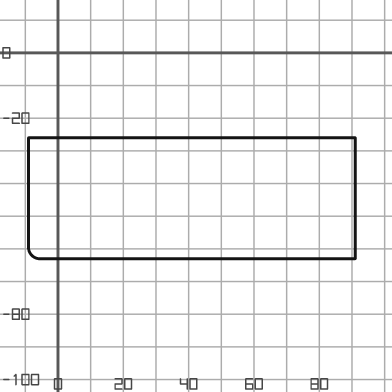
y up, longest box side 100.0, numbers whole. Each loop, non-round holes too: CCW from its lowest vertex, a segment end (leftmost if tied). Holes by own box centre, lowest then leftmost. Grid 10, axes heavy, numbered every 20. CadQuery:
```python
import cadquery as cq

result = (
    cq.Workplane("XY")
    .moveTo(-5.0, -63.0)
    .lineTo(91.0, -63.0)
    .lineTo(91.0, -26.0)
    .lineTo(-9.0, -26.0)
    .lineTo(-9.0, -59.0)
    .threePointArc((-8.0, -62.0), (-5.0, -63.0))
    .close()
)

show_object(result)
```